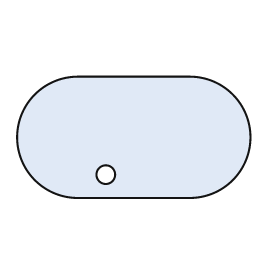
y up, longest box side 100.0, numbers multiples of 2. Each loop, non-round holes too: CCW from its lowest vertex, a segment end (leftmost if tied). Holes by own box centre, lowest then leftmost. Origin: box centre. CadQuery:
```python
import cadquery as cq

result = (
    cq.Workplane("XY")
    .moveTo(-24.0, -26.0)
    .lineTo(24.0, -26.0)
    .threePointArc((50.0, 0.0), (24.0, 26.0))
    .lineTo(-24.0, 26.0)
    .threePointArc((-50.0, 0.0), (-24.0, -26.0))
    .close()
    .moveTo(-12.0, -16.0)
    .circle(4.0)
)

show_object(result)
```